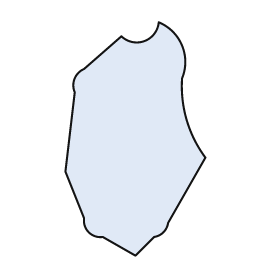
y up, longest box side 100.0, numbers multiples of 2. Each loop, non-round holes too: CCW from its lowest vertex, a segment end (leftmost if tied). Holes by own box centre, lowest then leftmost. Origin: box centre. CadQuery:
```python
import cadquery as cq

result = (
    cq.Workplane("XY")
    .moveTo(0.0, -50.0)
    .lineTo(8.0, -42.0)
    .threePointArc((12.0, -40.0), (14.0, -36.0))
    .lineTo(30.0, -8.0)
    .threePointArc((22.0, 8.0), (20.0, 26.0))
    .threePointArc((20.0, 40.0), (10.0, 50.0))
    .threePointArc((4.0, 42.0), (-6.0, 44.0))
    .lineTo(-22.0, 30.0)
    .threePointArc((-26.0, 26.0), (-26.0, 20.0))
    .lineTo(-30.0, -14.0)
    .lineTo(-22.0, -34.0)
    .threePointArc((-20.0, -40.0), (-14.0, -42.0))
    .close()
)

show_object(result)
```